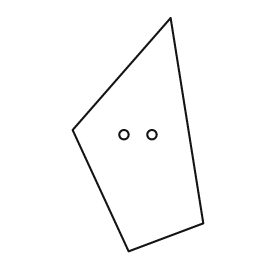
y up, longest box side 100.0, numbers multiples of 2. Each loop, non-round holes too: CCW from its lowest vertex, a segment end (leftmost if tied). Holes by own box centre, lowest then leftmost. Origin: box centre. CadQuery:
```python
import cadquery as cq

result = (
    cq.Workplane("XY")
    .moveTo(-4.0, -50.0)
    .lineTo(28.0, -38.0)
    .lineTo(14.0, 50.0)
    .lineTo(-28.0, 2.0)
    .close()
    .moveTo(-6.0, 0.0)
    .circle(2.0)
    .moveTo(6.0, 0.0)
    .circle(2.0)
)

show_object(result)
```